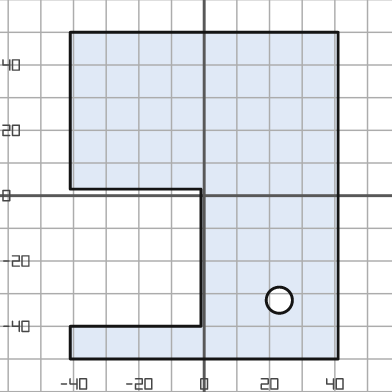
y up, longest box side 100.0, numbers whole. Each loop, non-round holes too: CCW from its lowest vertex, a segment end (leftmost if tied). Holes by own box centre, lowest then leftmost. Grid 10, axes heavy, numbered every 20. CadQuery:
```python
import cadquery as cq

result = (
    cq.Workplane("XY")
    .moveTo(-41.0, -50.0)
    .lineTo(41.0, -50.0)
    .lineTo(41.0, 50.0)
    .lineTo(-41.0, 50.0)
    .lineTo(-41.0, 2.0)
    .lineTo(-1.0, 2.0)
    .lineTo(-1.0, -40.0)
    .lineTo(-41.0, -40.0)
    .close()
    .moveTo(23.0, -32.0)
    .circle(4.0)
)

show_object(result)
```